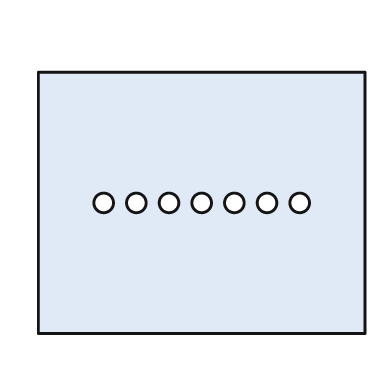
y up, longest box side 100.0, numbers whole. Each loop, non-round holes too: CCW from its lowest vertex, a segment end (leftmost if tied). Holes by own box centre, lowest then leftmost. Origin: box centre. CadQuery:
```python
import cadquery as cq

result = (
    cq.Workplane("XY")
    .moveTo(-50.0, -40.0)
    .lineTo(50.0, -40.0)
    .lineTo(50.0, 40.0)
    .lineTo(-50.0, 40.0)
    .close()
    .moveTo(-30.0, 0.0)
    .circle(3.0)
    .moveTo(-20.0, 0.0)
    .circle(3.0)
    .moveTo(-10.0, 0.0)
    .circle(3.0)
    .moveTo(0.0, 0.0)
    .circle(3.0)
    .moveTo(10.0, 0.0)
    .circle(3.0)
    .moveTo(20.0, 0.0)
    .circle(3.0)
    .moveTo(30.0, 0.0)
    .circle(3.0)
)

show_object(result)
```